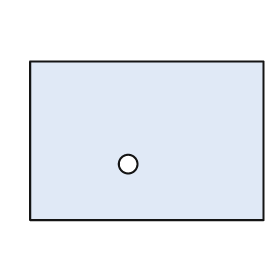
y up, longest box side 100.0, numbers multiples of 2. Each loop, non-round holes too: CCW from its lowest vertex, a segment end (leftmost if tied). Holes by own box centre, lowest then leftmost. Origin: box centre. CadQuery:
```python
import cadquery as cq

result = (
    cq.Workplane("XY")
    .moveTo(-50.0, -34.0)
    .lineTo(50.0, -34.0)
    .lineTo(50.0, 34.0)
    .lineTo(-50.0, 34.0)
    .close()
    .moveTo(-8.0, -10.0)
    .circle(4.0)
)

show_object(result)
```